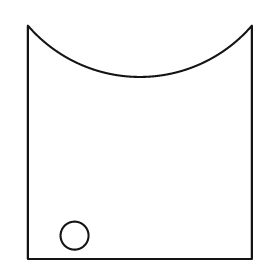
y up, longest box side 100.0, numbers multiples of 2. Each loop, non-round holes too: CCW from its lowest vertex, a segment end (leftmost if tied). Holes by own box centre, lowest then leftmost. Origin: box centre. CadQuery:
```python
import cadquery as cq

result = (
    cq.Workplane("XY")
    .moveTo(-48.0, -50.0)
    .lineTo(48.0, -50.0)
    .lineTo(48.0, 50.0)
    .threePointArc((0.0, 28.0), (-48.0, 50.0))
    .close()
    .moveTo(-28.0, -40.0)
    .circle(6.0)
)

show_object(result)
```